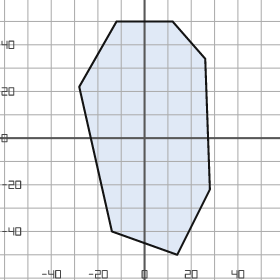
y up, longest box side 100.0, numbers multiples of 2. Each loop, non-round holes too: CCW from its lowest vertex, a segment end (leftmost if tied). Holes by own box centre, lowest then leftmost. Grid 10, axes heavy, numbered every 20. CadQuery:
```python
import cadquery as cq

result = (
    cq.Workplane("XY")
    .moveTo(14.0, -50.0)
    .lineTo(28.0, -22.0)
    .lineTo(26.0, 34.0)
    .lineTo(12.0, 50.0)
    .lineTo(-12.0, 50.0)
    .lineTo(-28.0, 22.0)
    .lineTo(-14.0, -40.0)
    .close()
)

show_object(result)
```